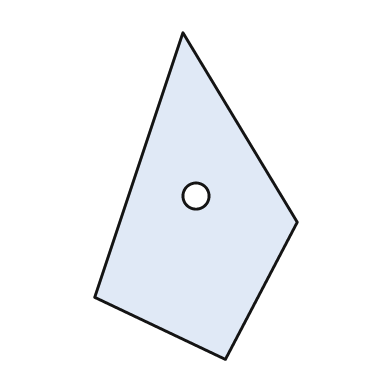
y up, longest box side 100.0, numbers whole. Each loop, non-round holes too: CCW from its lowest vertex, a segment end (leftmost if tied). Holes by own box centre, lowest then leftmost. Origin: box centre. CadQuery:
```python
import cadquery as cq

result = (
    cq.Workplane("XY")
    .moveTo(9.0, -50.0)
    .lineTo(31.0, -8.0)
    .lineTo(-4.0, 50.0)
    .lineTo(-31.0, -31.0)
    .close()
    .moveTo(0.0, 0.0)
    .circle(4.0)
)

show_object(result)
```